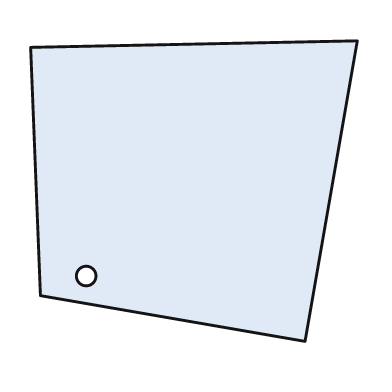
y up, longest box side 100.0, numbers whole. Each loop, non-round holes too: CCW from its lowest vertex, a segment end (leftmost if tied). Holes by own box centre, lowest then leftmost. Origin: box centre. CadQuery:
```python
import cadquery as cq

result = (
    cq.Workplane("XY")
    .moveTo(34.0, -46.0)
    .lineTo(50.0, 46.0)
    .lineTo(-50.0, 44.0)
    .lineTo(-47.0, -32.0)
    .close()
    .moveTo(-33.0, -26.0)
    .circle(3.0)
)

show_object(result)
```